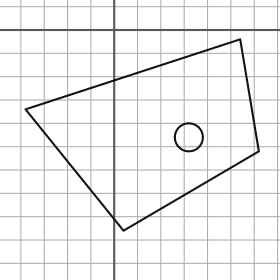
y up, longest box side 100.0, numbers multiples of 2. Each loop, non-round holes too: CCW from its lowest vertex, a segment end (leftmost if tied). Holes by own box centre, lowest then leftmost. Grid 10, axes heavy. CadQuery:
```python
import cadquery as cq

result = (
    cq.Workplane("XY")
    .moveTo(4.0, -86.0)
    .lineTo(62.0, -52.0)
    .lineTo(54.0, -4.0)
    .lineTo(-38.0, -34.0)
    .close()
    .moveTo(32.0, -46.0)
    .circle(6.0)
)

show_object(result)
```